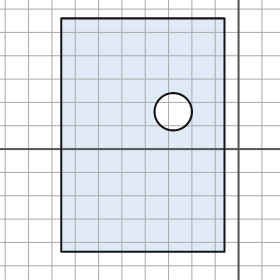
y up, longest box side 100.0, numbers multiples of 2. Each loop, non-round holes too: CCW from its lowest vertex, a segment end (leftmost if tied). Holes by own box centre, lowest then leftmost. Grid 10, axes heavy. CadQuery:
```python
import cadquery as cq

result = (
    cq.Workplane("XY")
    .moveTo(-76.0, -44.0)
    .lineTo(-6.0, -44.0)
    .lineTo(-6.0, 56.0)
    .lineTo(-76.0, 56.0)
    .close()
    .moveTo(-28.0, 16.0)
    .circle(8.0)
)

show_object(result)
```